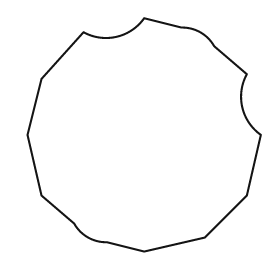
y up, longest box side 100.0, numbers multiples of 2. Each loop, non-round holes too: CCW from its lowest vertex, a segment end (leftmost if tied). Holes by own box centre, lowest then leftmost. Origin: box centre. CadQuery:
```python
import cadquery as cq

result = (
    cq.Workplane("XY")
    .moveTo(0.0, -50.0)
    .lineTo(26.0, -44.0)
    .lineTo(44.0, -26.0)
    .lineTo(50.0, 0.0)
    .threePointArc((42.0, 12.0), (44.0, 26.0))
    .lineTo(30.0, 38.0)
    .threePointArc((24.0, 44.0), (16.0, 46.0))
    .lineTo(0.0, 50.0)
    .threePointArc((-12.0, 42.0), (-26.0, 44.0))
    .lineTo(-44.0, 24.0)
    .lineTo(-50.0, 0.0)
    .lineTo(-44.0, -26.0)
    .lineTo(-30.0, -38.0)
    .threePointArc((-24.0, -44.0), (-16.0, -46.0))
    .close()
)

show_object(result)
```